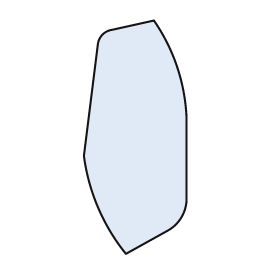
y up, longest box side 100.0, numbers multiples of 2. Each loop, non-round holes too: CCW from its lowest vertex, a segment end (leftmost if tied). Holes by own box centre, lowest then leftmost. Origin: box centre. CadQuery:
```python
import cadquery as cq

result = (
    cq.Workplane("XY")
    .moveTo(-4.0, -50.0)
    .lineTo(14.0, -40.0)
    .threePointArc((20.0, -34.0), (22.0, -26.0))
    .lineTo(22.0, 8.0)
    .threePointArc((18.0, 30.0), (8.0, 50.0))
    .lineTo(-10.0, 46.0)
    .threePointArc((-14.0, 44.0), (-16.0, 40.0))
    .lineTo(-22.0, -8.0)
    .threePointArc((-16.0, -30.0), (-4.0, -50.0))
    .close()
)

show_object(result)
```